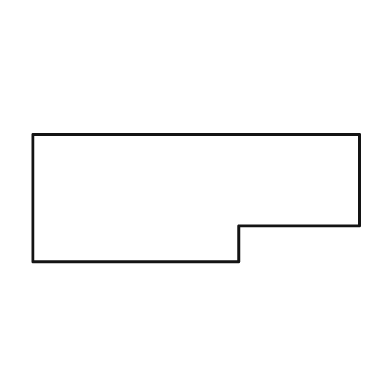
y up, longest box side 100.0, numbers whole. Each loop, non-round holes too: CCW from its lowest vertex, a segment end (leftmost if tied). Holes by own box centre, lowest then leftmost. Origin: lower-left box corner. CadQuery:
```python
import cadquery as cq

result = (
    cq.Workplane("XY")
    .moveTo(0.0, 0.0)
    .lineTo(63.0, 0.0)
    .lineTo(63.0, 11.0)
    .lineTo(100.0, 11.0)
    .lineTo(100.0, 39.0)
    .lineTo(0.0, 39.0)
    .close()
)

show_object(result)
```